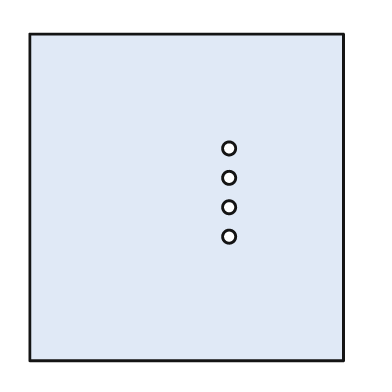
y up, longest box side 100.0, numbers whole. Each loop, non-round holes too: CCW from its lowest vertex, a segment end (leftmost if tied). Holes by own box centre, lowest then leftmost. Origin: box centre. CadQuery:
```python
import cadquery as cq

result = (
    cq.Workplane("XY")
    .moveTo(-48.0, -50.0)
    .lineTo(48.0, -50.0)
    .lineTo(48.0, 50.0)
    .lineTo(-48.0, 50.0)
    .close()
    .moveTo(13.0, -12.0)
    .circle(2.0)
    .moveTo(13.0, -3.0)
    .circle(2.0)
    .moveTo(13.0, 6.0)
    .circle(2.0)
    .moveTo(13.0, 15.0)
    .circle(2.0)
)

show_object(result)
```